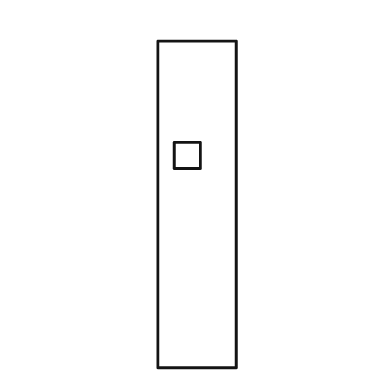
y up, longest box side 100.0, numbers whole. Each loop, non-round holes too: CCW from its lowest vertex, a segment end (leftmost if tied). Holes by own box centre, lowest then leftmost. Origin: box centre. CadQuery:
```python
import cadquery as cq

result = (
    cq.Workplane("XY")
    .moveTo(-12.0, -50.0)
    .lineTo(12.0, -50.0)
    .lineTo(12.0, 50.0)
    .lineTo(-12.0, 50.0)
    .close()
    .moveTo(-7.0, 11.0)
    .lineTo(1.0, 11.0)
    .lineTo(1.0, 19.0)
    .lineTo(-7.0, 19.0)
    .close()
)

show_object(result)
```